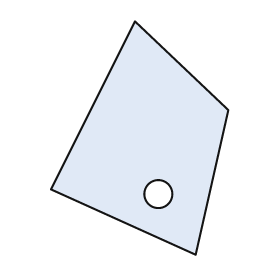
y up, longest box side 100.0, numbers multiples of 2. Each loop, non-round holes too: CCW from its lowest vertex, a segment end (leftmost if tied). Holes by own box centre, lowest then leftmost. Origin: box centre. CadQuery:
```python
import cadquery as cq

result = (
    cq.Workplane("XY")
    .moveTo(24.0, -50.0)
    .lineTo(38.0, 12.0)
    .lineTo(-2.0, 50.0)
    .lineTo(-38.0, -22.0)
    .close()
    .moveTo(8.0, -24.0)
    .circle(6.0)
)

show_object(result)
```